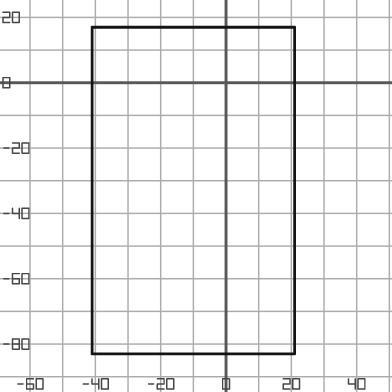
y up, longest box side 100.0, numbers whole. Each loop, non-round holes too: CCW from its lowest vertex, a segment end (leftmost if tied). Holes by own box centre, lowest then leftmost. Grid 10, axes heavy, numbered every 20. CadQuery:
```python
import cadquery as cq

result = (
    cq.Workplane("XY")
    .moveTo(-41.0, -83.0)
    .lineTo(21.0, -83.0)
    .lineTo(21.0, 17.0)
    .lineTo(-41.0, 17.0)
    .close()
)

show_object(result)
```